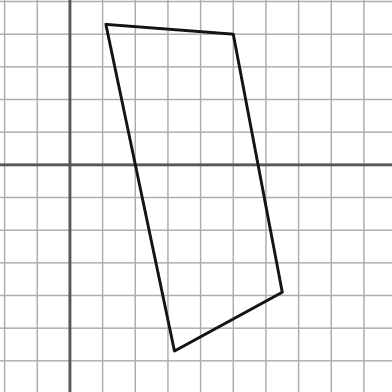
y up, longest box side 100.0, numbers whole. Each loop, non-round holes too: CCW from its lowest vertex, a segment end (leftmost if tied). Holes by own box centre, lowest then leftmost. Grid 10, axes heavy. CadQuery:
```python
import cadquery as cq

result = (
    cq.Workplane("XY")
    .moveTo(32.0, -57.0)
    .lineTo(65.0, -39.0)
    .lineTo(50.0, 40.0)
    .lineTo(11.0, 43.0)
    .close()
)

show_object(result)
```